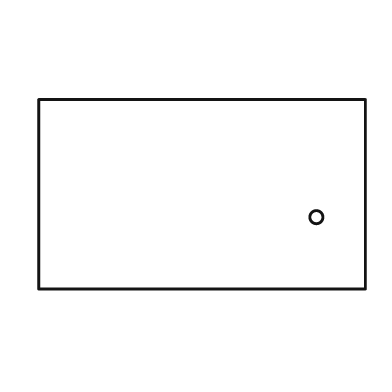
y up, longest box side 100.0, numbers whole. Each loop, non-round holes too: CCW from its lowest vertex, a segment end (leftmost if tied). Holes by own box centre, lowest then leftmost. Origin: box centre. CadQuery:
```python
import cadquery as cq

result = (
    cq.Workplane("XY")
    .moveTo(-50.0, -29.0)
    .lineTo(50.0, -29.0)
    .lineTo(50.0, 29.0)
    .lineTo(-50.0, 29.0)
    .close()
    .moveTo(35.0, -7.0)
    .circle(2.0)
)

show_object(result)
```